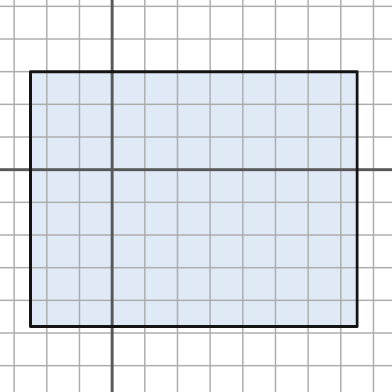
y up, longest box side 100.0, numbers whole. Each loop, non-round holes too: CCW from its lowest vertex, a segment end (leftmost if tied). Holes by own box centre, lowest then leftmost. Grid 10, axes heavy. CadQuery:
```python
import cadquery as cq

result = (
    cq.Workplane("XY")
    .moveTo(-25.0, -48.0)
    .lineTo(75.0, -48.0)
    .lineTo(75.0, 30.0)
    .lineTo(-25.0, 30.0)
    .close()
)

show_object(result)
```